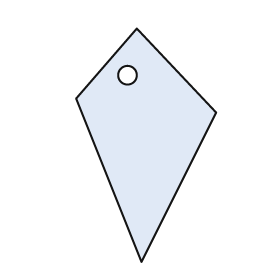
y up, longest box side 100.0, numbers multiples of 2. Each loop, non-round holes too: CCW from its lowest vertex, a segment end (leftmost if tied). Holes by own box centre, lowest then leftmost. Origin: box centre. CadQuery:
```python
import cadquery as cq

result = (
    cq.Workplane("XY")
    .moveTo(-2.0, -50.0)
    .lineTo(30.0, 14.0)
    .lineTo(-4.0, 50.0)
    .lineTo(-30.0, 20.0)
    .close()
    .moveTo(-8.0, 30.0)
    .circle(4.0)
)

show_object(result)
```